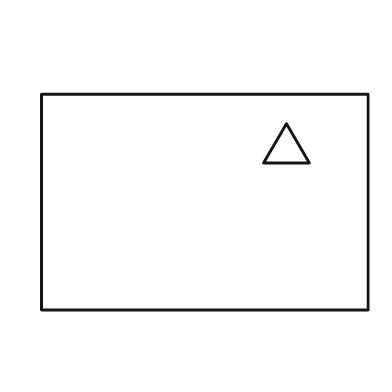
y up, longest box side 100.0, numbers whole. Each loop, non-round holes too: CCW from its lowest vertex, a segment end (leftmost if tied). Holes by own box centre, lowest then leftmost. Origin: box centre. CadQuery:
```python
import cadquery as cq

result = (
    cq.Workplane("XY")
    .moveTo(-50.0, -33.0)
    .lineTo(50.0, -33.0)
    .lineTo(50.0, 33.0)
    .lineTo(-50.0, 33.0)
    .close()
    .moveTo(18.0, 12.0)
    .lineTo(32.0, 12.0)
    .lineTo(25.0, 24.0)
    .close()
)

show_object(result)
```